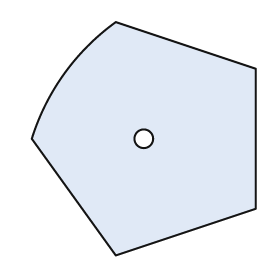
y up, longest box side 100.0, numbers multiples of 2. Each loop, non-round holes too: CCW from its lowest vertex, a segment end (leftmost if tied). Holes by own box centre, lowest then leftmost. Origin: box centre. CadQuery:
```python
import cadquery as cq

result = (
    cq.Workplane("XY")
    .moveTo(-12.0, -50.0)
    .lineTo(48.0, -30.0)
    .lineTo(48.0, 30.0)
    .lineTo(-12.0, 50.0)
    .threePointArc((-34.0, 28.0), (-48.0, 0.0))
    .close()
    .moveTo(0.0, 0.0)
    .circle(4.0)
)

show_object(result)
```